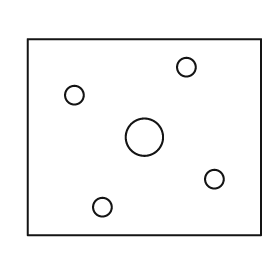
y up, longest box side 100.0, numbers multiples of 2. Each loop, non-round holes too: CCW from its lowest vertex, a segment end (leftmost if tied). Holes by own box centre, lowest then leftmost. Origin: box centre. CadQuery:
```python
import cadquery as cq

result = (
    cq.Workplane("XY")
    .moveTo(-50.0, -42.0)
    .lineTo(50.0, -42.0)
    .lineTo(50.0, 42.0)
    .lineTo(-50.0, 42.0)
    .close()
    .moveTo(-18.0, -30.0)
    .circle(4.0)
    .moveTo(30.0, -18.0)
    .circle(4.0)
    .moveTo(0.0, 0.0)
    .circle(8.0)
    .moveTo(-30.0, 18.0)
    .circle(4.0)
    .moveTo(18.0, 30.0)
    .circle(4.0)
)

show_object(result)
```